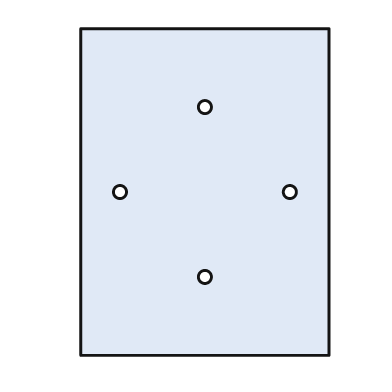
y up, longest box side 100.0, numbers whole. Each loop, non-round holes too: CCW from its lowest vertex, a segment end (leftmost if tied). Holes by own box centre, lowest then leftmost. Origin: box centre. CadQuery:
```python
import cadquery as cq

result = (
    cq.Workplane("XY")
    .moveTo(-38.0, -50.0)
    .lineTo(38.0, -50.0)
    .lineTo(38.0, 50.0)
    .lineTo(-38.0, 50.0)
    .close()
    .moveTo(0.0, -26.0)
    .circle(2.0)
    .moveTo(-26.0, 0.0)
    .circle(2.0)
    .moveTo(26.0, 0.0)
    .circle(2.0)
    .moveTo(0.0, 26.0)
    .circle(2.0)
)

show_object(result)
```